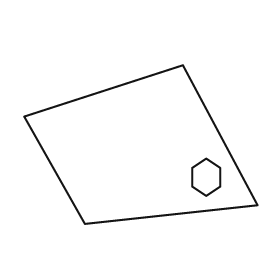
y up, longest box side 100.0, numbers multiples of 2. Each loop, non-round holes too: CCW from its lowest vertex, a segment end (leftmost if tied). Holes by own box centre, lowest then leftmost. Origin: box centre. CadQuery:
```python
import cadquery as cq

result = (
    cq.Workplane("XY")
    .moveTo(-24.0, -34.0)
    .lineTo(50.0, -26.0)
    .lineTo(18.0, 34.0)
    .lineTo(-50.0, 12.0)
    .close()
    .moveTo(28.0, -22.0)
    .lineTo(34.0, -18.0)
    .lineTo(34.0, -10.0)
    .lineTo(28.0, -6.0)
    .lineTo(22.0, -10.0)
    .lineTo(22.0, -18.0)
    .close()
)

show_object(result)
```